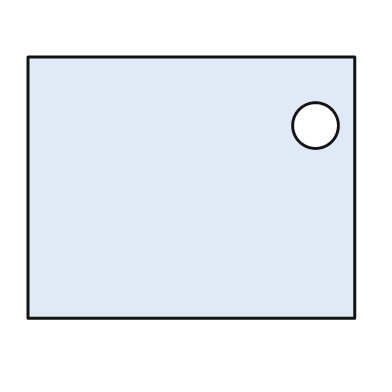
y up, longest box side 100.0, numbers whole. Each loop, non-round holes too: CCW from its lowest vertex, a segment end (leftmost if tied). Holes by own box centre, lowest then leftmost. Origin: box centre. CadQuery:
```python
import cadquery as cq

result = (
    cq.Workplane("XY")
    .moveTo(-50.0, -40.0)
    .lineTo(50.0, -40.0)
    .lineTo(50.0, 40.0)
    .lineTo(-50.0, 40.0)
    .close()
    .moveTo(38.0, 19.0)
    .circle(7.0)
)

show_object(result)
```